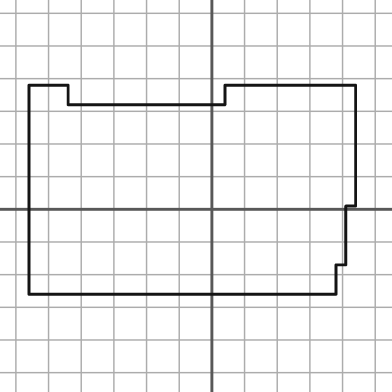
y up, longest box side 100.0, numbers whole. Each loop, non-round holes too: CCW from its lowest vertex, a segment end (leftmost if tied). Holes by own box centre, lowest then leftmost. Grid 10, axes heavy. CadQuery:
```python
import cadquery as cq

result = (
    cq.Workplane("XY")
    .moveTo(-56.0, -26.0)
    .lineTo(38.0, -26.0)
    .lineTo(38.0, -17.0)
    .lineTo(41.0, -17.0)
    .lineTo(41.0, 1.0)
    .lineTo(44.0, 1.0)
    .lineTo(44.0, 38.0)
    .lineTo(4.0, 38.0)
    .lineTo(4.0, 32.0)
    .lineTo(-44.0, 32.0)
    .lineTo(-44.0, 38.0)
    .lineTo(-56.0, 38.0)
    .close()
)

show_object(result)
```